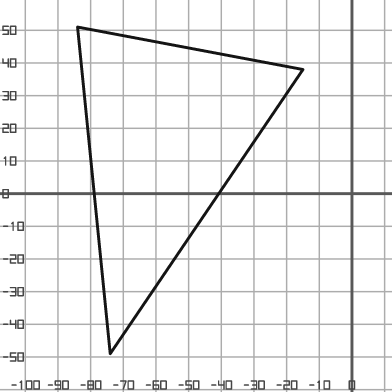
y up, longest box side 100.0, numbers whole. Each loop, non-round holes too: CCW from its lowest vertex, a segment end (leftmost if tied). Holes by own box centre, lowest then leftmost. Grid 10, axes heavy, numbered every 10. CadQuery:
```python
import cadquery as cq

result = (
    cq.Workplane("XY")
    .moveTo(-74.0, -49.0)
    .lineTo(-15.0, 38.0)
    .lineTo(-84.0, 51.0)
    .close()
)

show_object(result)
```